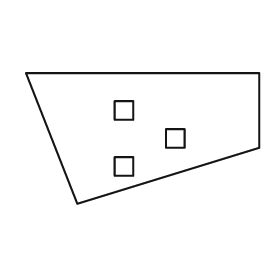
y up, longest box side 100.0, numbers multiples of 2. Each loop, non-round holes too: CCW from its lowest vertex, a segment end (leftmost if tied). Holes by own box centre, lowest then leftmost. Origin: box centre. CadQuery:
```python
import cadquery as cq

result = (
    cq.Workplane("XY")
    .moveTo(-28.0, -28.0)
    .lineTo(50.0, -4.0)
    .lineTo(50.0, 28.0)
    .lineTo(-50.0, 28.0)
    .close()
    .moveTo(-12.0, -16.0)
    .lineTo(-4.0, -16.0)
    .lineTo(-4.0, -8.0)
    .lineTo(-12.0, -8.0)
    .close()
    .moveTo(10.0, -4.0)
    .lineTo(18.0, -4.0)
    .lineTo(18.0, 4.0)
    .lineTo(10.0, 4.0)
    .close()
    .moveTo(-12.0, 8.0)
    .lineTo(-4.0, 8.0)
    .lineTo(-4.0, 16.0)
    .lineTo(-12.0, 16.0)
    .close()
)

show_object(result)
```